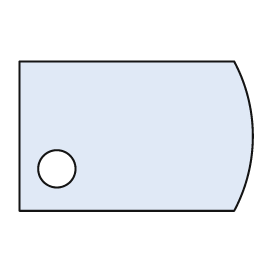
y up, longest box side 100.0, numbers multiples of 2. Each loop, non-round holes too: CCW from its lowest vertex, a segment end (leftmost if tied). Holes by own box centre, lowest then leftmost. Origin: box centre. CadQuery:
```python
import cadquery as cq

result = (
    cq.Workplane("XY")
    .moveTo(-50.0, -32.0)
    .lineTo(42.0, -32.0)
    .threePointArc((50.0, 0.0), (42.0, 32.0))
    .lineTo(-50.0, 32.0)
    .close()
    .moveTo(-34.0, -14.0)
    .circle(8.0)
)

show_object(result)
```